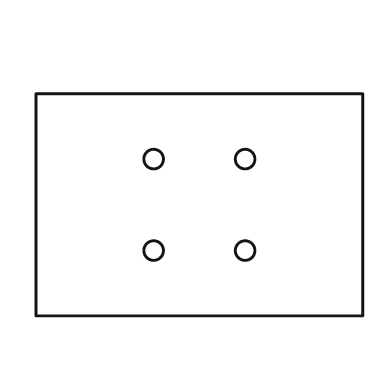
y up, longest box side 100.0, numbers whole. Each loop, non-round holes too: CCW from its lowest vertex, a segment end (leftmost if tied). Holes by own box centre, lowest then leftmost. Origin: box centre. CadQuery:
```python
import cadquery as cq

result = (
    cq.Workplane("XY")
    .moveTo(-50.0, -34.0)
    .lineTo(50.0, -34.0)
    .lineTo(50.0, 34.0)
    .lineTo(-50.0, 34.0)
    .close()
    .moveTo(-14.0, -14.0)
    .circle(3.0)
    .moveTo(14.0, -14.0)
    .circle(3.0)
    .moveTo(-14.0, 14.0)
    .circle(3.0)
    .moveTo(14.0, 14.0)
    .circle(3.0)
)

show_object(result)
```